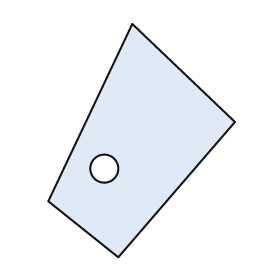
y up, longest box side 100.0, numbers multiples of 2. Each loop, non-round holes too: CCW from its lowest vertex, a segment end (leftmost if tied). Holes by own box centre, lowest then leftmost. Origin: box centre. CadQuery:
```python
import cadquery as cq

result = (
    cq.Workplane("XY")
    .moveTo(-10.0, -50.0)
    .lineTo(40.0, 8.0)
    .lineTo(-4.0, 50.0)
    .lineTo(-40.0, -26.0)
    .close()
    .moveTo(-16.0, -12.0)
    .circle(6.0)
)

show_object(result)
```